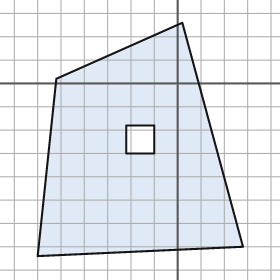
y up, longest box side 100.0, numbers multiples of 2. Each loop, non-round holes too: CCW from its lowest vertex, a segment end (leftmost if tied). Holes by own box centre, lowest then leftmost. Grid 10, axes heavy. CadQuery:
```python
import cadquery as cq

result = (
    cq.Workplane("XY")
    .moveTo(-60.0, -74.0)
    .lineTo(28.0, -70.0)
    .lineTo(2.0, 26.0)
    .lineTo(-52.0, 2.0)
    .close()
    .moveTo(-22.0, -30.0)
    .lineTo(-10.0, -30.0)
    .lineTo(-10.0, -18.0)
    .lineTo(-22.0, -18.0)
    .close()
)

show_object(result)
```